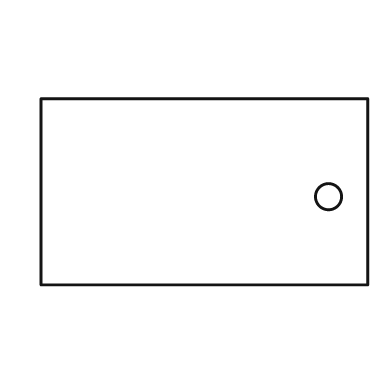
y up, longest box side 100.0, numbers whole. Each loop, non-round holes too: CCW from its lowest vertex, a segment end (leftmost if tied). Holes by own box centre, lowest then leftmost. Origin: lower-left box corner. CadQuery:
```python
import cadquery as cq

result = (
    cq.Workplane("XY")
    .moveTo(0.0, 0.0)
    .lineTo(100.0, 0.0)
    .lineTo(100.0, 57.0)
    .lineTo(0.0, 57.0)
    .close()
    .moveTo(88.0, 27.0)
    .circle(4.0)
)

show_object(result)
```